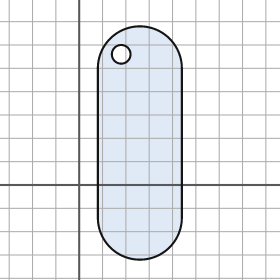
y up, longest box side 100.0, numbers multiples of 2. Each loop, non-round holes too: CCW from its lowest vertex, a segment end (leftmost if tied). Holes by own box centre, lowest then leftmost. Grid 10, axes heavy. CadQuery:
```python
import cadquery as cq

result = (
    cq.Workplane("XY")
    .moveTo(8.0, -14.0)
    .threePointArc((26.0, -32.0), (44.0, -14.0))
    .lineTo(44.0, 50.0)
    .threePointArc((26.0, 68.0), (8.0, 50.0))
    .close()
    .moveTo(18.0, 56.0)
    .circle(4.0)
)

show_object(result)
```